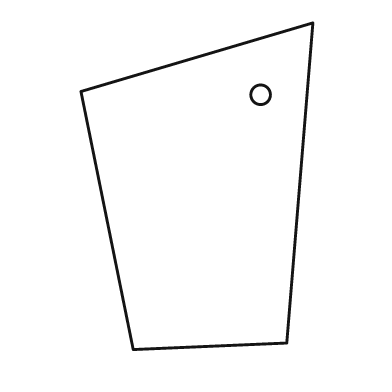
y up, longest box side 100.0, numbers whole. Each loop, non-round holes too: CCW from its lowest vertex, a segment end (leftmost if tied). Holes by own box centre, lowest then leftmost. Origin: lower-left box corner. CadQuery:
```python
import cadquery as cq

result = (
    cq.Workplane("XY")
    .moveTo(16.0, 0.0)
    .lineTo(63.0, 2.0)
    .lineTo(71.0, 100.0)
    .lineTo(0.0, 79.0)
    .close()
    .moveTo(55.0, 78.0)
    .circle(3.0)
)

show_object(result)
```